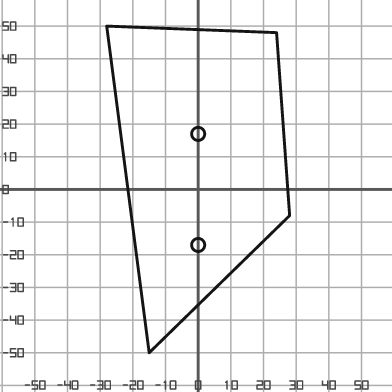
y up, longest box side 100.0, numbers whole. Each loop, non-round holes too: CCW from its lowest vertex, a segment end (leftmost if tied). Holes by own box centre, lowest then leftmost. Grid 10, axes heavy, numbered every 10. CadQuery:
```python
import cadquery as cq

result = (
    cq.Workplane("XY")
    .moveTo(-15.0, -50.0)
    .lineTo(28.0, -8.0)
    .lineTo(24.0, 48.0)
    .lineTo(-28.0, 50.0)
    .close()
    .moveTo(0.0, -17.0)
    .circle(2.0)
    .moveTo(0.0, 17.0)
    .circle(2.0)
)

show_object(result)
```